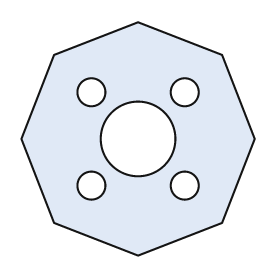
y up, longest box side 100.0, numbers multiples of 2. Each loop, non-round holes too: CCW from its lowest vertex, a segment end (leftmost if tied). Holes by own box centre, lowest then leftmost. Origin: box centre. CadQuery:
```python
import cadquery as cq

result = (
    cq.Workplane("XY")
    .moveTo(0.0, -50.0)
    .lineTo(36.0, -36.0)
    .lineTo(50.0, 0.0)
    .lineTo(36.0, 36.0)
    .lineTo(0.0, 50.0)
    .lineTo(-36.0, 36.0)
    .lineTo(-50.0, 0.0)
    .lineTo(-36.0, -36.0)
    .close()
    .moveTo(-20.0, -20.0)
    .circle(6.0)
    .moveTo(20.0, -20.0)
    .circle(6.0)
    .moveTo(0.0, 0.0)
    .circle(16.0)
    .moveTo(-20.0, 20.0)
    .circle(6.0)
    .moveTo(20.0, 20.0)
    .circle(6.0)
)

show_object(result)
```